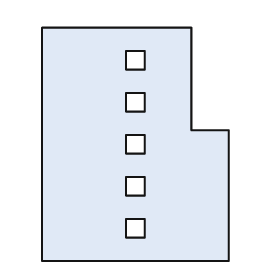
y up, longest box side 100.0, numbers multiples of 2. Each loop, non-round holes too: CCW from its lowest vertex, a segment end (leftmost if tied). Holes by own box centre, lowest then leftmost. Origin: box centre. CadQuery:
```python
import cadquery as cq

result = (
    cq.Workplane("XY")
    .moveTo(-40.0, -50.0)
    .lineTo(40.0, -50.0)
    .lineTo(40.0, 6.0)
    .lineTo(24.0, 6.0)
    .lineTo(24.0, 50.0)
    .lineTo(-40.0, 50.0)
    .close()
    .moveTo(-4.0, -40.0)
    .lineTo(4.0, -40.0)
    .lineTo(4.0, -32.0)
    .lineTo(-4.0, -32.0)
    .close()
    .moveTo(-4.0, -22.0)
    .lineTo(4.0, -22.0)
    .lineTo(4.0, -14.0)
    .lineTo(-4.0, -14.0)
    .close()
    .moveTo(-4.0, -4.0)
    .lineTo(4.0, -4.0)
    .lineTo(4.0, 4.0)
    .lineTo(-4.0, 4.0)
    .close()
    .moveTo(-4.0, 14.0)
    .lineTo(4.0, 14.0)
    .lineTo(4.0, 22.0)
    .lineTo(-4.0, 22.0)
    .close()
    .moveTo(-4.0, 32.0)
    .lineTo(4.0, 32.0)
    .lineTo(4.0, 40.0)
    .lineTo(-4.0, 40.0)
    .close()
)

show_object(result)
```